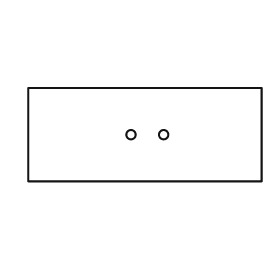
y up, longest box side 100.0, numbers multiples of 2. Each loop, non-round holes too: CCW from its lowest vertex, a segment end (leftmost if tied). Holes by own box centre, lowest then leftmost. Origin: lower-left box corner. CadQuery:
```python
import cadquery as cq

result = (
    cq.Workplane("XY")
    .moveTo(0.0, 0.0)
    .lineTo(100.0, 0.0)
    .lineTo(100.0, 40.0)
    .lineTo(0.0, 40.0)
    .close()
    .moveTo(44.0, 20.0)
    .circle(2.0)
    .moveTo(58.0, 20.0)
    .circle(2.0)
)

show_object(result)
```